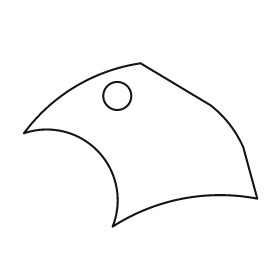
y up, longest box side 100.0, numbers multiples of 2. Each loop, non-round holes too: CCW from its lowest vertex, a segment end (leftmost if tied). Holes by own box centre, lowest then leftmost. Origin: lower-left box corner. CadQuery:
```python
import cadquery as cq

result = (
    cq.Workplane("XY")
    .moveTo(38.0, 0.0)
    .threePointArc((68.0, 12.0), (100.0, 12.0))
    .lineTo(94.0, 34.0)
    .threePointArc((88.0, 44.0), (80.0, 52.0))
    .lineTo(50.0, 70.0)
    .threePointArc((22.0, 60.0), (0.0, 40.0))
    .threePointArc((32.0, 32.0), (38.0, 0.0))
    .close()
    .moveTo(40.0, 56.0)
    .circle(6.0)
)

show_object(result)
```